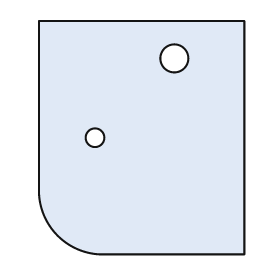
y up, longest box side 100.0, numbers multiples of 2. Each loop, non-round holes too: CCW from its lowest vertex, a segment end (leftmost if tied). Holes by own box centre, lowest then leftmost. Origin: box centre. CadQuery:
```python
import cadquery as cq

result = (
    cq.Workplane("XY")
    .moveTo(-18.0, -50.0)
    .lineTo(44.0, -50.0)
    .lineTo(44.0, 50.0)
    .lineTo(-44.0, 50.0)
    .lineTo(-44.0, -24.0)
    .threePointArc((-36.0, -42.0), (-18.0, -50.0))
    .close()
    .moveTo(-20.0, 0.0)
    .circle(4.0)
    .moveTo(14.0, 34.0)
    .circle(6.0)
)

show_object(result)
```